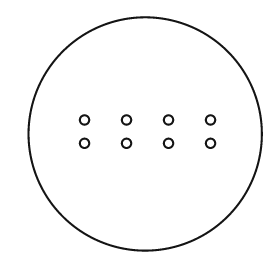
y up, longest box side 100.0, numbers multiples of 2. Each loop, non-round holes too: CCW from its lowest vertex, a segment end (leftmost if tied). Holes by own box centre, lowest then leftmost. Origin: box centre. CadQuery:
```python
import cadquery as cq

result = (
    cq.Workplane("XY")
    .moveTo(0.0, 0.0)
    .circle(50.0)
    .moveTo(-26.0, -4.0)
    .circle(2.0)
    .moveTo(-8.0, -4.0)
    .circle(2.0)
    .moveTo(10.0, -4.0)
    .circle(2.0)
    .moveTo(28.0, -4.0)
    .circle(2.0)
    .moveTo(-26.0, 6.0)
    .circle(2.0)
    .moveTo(-8.0, 6.0)
    .circle(2.0)
    .moveTo(10.0, 6.0)
    .circle(2.0)
    .moveTo(28.0, 6.0)
    .circle(2.0)
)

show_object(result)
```